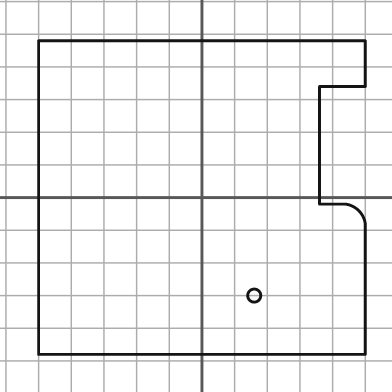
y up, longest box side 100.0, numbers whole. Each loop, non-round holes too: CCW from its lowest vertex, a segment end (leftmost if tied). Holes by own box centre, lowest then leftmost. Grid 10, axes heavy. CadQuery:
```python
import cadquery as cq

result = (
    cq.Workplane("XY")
    .moveTo(-50.0, -48.0)
    .lineTo(50.0, -48.0)
    .lineTo(50.0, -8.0)
    .threePointArc((48.0, -4.0), (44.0, -2.0))
    .lineTo(36.0, -2.0)
    .lineTo(36.0, 34.0)
    .lineTo(50.0, 34.0)
    .lineTo(50.0, 48.0)
    .lineTo(-50.0, 48.0)
    .close()
    .moveTo(16.0, -30.0)
    .circle(2.0)
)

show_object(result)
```